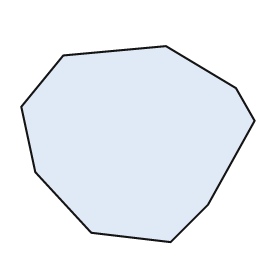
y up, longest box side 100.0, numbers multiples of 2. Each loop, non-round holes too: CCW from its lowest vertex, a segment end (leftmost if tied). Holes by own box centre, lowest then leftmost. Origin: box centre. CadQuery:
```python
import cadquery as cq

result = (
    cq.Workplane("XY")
    .moveTo(14.0, -42.0)
    .lineTo(30.0, -26.0)
    .lineTo(50.0, 10.0)
    .lineTo(42.0, 24.0)
    .lineTo(12.0, 42.0)
    .lineTo(-32.0, 38.0)
    .lineTo(-50.0, 16.0)
    .lineTo(-44.0, -12.0)
    .lineTo(-20.0, -38.0)
    .close()
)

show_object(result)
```